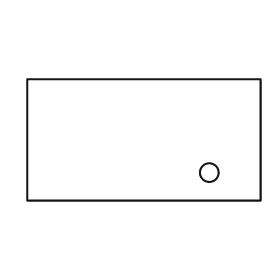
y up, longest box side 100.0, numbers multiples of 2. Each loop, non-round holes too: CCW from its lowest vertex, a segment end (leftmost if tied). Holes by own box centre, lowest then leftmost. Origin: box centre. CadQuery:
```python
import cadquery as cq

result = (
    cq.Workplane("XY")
    .moveTo(-50.0, -26.0)
    .lineTo(50.0, -26.0)
    .lineTo(50.0, 26.0)
    .lineTo(-50.0, 26.0)
    .close()
    .moveTo(28.0, -14.0)
    .circle(4.0)
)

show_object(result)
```